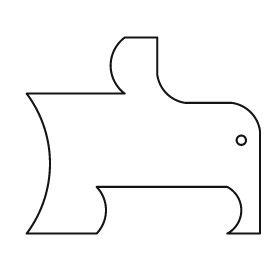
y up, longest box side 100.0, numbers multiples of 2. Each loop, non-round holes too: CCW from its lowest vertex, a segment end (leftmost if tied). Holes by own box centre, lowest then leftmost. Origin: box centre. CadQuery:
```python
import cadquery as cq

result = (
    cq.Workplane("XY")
    .moveTo(-50.0, -42.0)
    .lineTo(-20.0, -42.0)
    .threePointArc((-16.0, -32.0), (-20.0, -22.0))
    .lineTo(36.0, -22.0)
    .threePointArc((42.0, -32.0), (36.0, -42.0))
    .lineTo(50.0, -42.0)
    .lineTo(50.0, 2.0)
    .threePointArc((46.0, 10.0), (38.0, 14.0))
    .lineTo(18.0, 14.0)
    .threePointArc((10.0, 18.0), (6.0, 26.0))
    .lineTo(6.0, 42.0)
    .lineTo(-8.0, 42.0)
    .threePointArc((-14.0, 30.0), (-8.0, 18.0))
    .lineTo(-50.0, 18.0)
    .threePointArc((-40.0, -12.0), (-50.0, -42.0))
    .close()
    .moveTo(42.0, -2.0)
    .circle(2.0)
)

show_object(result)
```